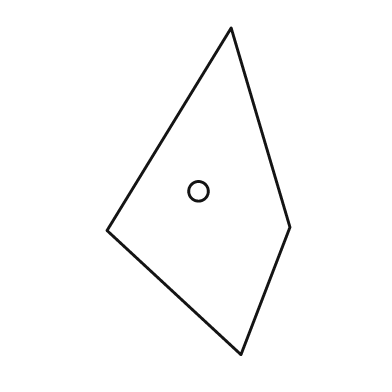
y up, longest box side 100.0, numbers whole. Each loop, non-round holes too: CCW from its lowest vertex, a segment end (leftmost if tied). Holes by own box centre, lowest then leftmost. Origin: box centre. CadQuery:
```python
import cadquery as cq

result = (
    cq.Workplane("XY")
    .moveTo(13.0, -50.0)
    .lineTo(28.0, -11.0)
    .lineTo(10.0, 50.0)
    .lineTo(-28.0, -12.0)
    .close()
    .moveTo(0.0, 0.0)
    .circle(3.0)
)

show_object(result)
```